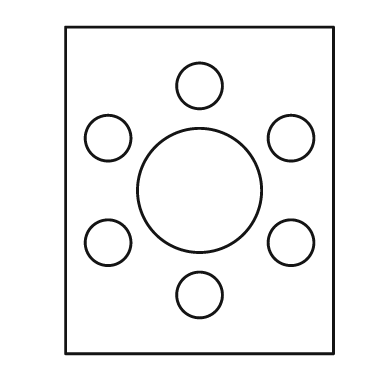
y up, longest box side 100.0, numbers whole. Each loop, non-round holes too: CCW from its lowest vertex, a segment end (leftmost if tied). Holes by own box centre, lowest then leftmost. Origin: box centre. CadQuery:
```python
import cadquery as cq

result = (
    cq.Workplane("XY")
    .moveTo(-41.0, -50.0)
    .lineTo(41.0, -50.0)
    .lineTo(41.0, 50.0)
    .lineTo(-41.0, 50.0)
    .close()
    .moveTo(0.0, -32.0)
    .circle(7.0)
    .moveTo(-28.0, -16.0)
    .circle(7.0)
    .moveTo(28.0, -16.0)
    .circle(7.0)
    .moveTo(0.0, 0.0)
    .circle(19.0)
    .moveTo(-28.0, 16.0)
    .circle(7.0)
    .moveTo(28.0, 16.0)
    .circle(7.0)
    .moveTo(0.0, 32.0)
    .circle(7.0)
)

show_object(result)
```